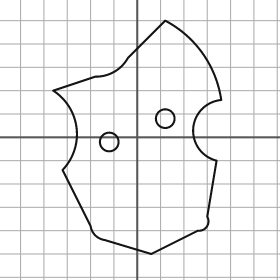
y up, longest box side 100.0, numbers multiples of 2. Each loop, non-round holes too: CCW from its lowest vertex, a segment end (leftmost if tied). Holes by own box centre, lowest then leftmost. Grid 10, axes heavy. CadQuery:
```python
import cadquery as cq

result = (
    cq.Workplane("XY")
    .moveTo(6.0, -50.0)
    .lineTo(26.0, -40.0)
    .threePointArc((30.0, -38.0), (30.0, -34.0))
    .lineTo(34.0, -10.0)
    .threePointArc((24.0, 4.0), (36.0, 16.0))
    .threePointArc((28.0, 36.0), (12.0, 50.0))
    .lineTo(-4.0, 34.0)
    .threePointArc((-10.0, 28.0), (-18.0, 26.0))
    .lineTo(-36.0, 20.0)
    .threePointArc((-26.0, 4.0), (-32.0, -14.0))
    .lineTo(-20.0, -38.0)
    .threePointArc((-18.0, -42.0), (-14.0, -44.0))
    .close()
    .moveTo(-12.0, -2.0)
    .circle(4.0)
    .moveTo(12.0, 8.0)
    .circle(4.0)
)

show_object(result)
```